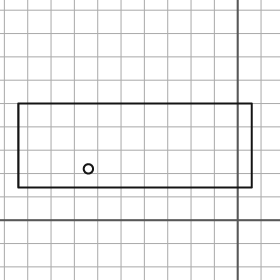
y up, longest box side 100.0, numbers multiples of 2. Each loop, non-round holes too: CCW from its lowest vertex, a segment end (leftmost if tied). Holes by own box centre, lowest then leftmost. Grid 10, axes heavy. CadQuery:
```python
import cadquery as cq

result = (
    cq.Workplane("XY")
    .moveTo(-94.0, 14.0)
    .lineTo(6.0, 14.0)
    .lineTo(6.0, 50.0)
    .lineTo(-94.0, 50.0)
    .close()
    .moveTo(-64.0, 22.0)
    .circle(2.0)
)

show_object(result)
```